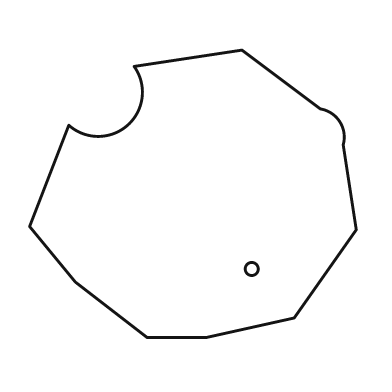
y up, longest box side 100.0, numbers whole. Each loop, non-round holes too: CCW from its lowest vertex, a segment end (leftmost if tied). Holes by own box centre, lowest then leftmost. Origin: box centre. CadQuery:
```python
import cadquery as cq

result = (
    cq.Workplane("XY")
    .moveTo(-14.0, -44.0)
    .lineTo(4.0, -44.0)
    .lineTo(31.0, -38.0)
    .lineTo(50.0, -11.0)
    .lineTo(46.0, 15.0)
    .threePointArc((45.0, 22.0), (39.0, 26.0))
    .lineTo(15.0, 44.0)
    .lineTo(-18.0, 39.0)
    .threePointArc((-20.0, 21.0), (-38.0, 21.0))
    .lineTo(-50.0, -10.0)
    .lineTo(-36.0, -27.0)
    .close()
    .moveTo(18.0, -23.0)
    .circle(2.0)
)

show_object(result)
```